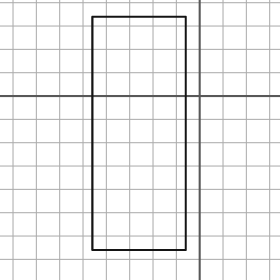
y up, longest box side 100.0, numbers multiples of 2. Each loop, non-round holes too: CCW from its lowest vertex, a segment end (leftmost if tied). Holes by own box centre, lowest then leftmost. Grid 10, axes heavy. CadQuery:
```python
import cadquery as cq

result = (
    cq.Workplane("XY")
    .moveTo(-46.0, -66.0)
    .lineTo(-6.0, -66.0)
    .lineTo(-6.0, 34.0)
    .lineTo(-46.0, 34.0)
    .close()
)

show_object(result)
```